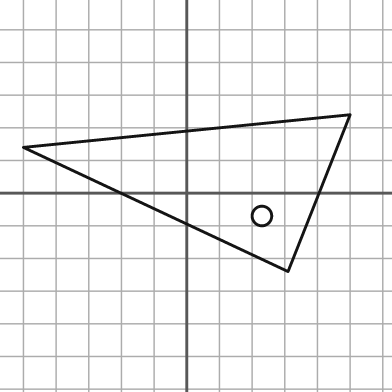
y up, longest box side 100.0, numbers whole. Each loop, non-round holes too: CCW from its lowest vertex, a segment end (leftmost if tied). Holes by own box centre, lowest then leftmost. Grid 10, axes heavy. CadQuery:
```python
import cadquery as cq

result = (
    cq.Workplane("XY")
    .moveTo(31.0, -24.0)
    .lineTo(50.0, 24.0)
    .lineTo(-50.0, 14.0)
    .close()
    .moveTo(23.0, -7.0)
    .circle(3.0)
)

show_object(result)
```